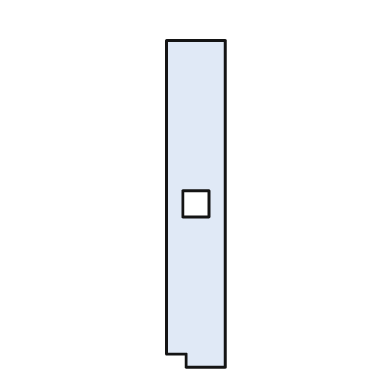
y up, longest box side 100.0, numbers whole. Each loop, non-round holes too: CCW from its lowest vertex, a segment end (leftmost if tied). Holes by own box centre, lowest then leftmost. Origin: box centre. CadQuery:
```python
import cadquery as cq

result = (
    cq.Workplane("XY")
    .moveTo(-3.0, -50.0)
    .lineTo(9.0, -50.0)
    .lineTo(9.0, 50.0)
    .lineTo(-9.0, 50.0)
    .lineTo(-9.0, -46.0)
    .lineTo(-3.0, -46.0)
    .close()
    .moveTo(-4.0, -4.0)
    .lineTo(4.0, -4.0)
    .lineTo(4.0, 4.0)
    .lineTo(-4.0, 4.0)
    .close()
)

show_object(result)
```